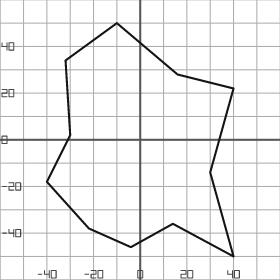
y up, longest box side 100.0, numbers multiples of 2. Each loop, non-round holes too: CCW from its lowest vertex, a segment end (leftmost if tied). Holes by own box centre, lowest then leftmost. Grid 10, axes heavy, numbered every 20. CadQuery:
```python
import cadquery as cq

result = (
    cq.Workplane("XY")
    .moveTo(40.0, -50.0)
    .lineTo(30.0, -14.0)
    .lineTo(40.0, 22.0)
    .lineTo(16.0, 28.0)
    .lineTo(-10.0, 50.0)
    .lineTo(-32.0, 34.0)
    .lineTo(-30.0, 2.0)
    .lineTo(-40.0, -18.0)
    .lineTo(-22.0, -38.0)
    .lineTo(-4.0, -46.0)
    .lineTo(14.0, -36.0)
    .close()
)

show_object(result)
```